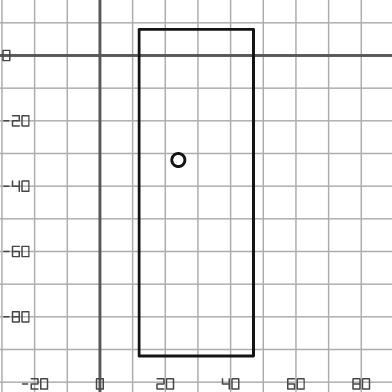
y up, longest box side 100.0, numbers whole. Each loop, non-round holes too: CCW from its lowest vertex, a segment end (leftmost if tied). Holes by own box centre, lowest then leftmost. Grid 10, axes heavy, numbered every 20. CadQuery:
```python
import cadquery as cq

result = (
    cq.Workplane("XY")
    .moveTo(12.0, -92.0)
    .lineTo(47.0, -92.0)
    .lineTo(47.0, 8.0)
    .lineTo(12.0, 8.0)
    .close()
    .moveTo(24.0, -32.0)
    .circle(2.0)
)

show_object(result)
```